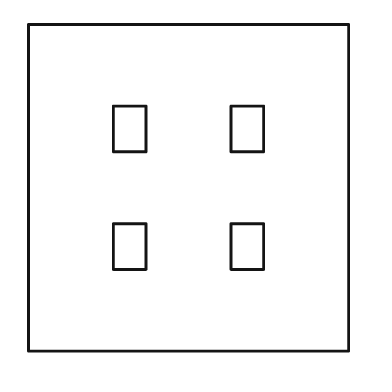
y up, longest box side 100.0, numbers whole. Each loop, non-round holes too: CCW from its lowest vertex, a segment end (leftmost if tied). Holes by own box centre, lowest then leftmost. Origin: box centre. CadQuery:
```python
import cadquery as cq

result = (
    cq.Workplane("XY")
    .moveTo(-49.0, -50.0)
    .lineTo(49.0, -50.0)
    .lineTo(49.0, 50.0)
    .lineTo(-49.0, 50.0)
    .close()
    .moveTo(-23.0, -25.0)
    .lineTo(-13.0, -25.0)
    .lineTo(-13.0, -11.0)
    .lineTo(-23.0, -11.0)
    .close()
    .moveTo(13.0, -25.0)
    .lineTo(23.0, -25.0)
    .lineTo(23.0, -11.0)
    .lineTo(13.0, -11.0)
    .close()
    .moveTo(-23.0, 11.0)
    .lineTo(-13.0, 11.0)
    .lineTo(-13.0, 25.0)
    .lineTo(-23.0, 25.0)
    .close()
    .moveTo(13.0, 11.0)
    .lineTo(23.0, 11.0)
    .lineTo(23.0, 25.0)
    .lineTo(13.0, 25.0)
    .close()
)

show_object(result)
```